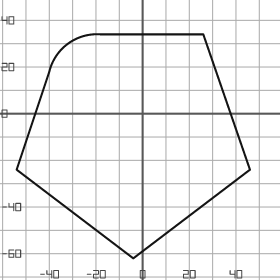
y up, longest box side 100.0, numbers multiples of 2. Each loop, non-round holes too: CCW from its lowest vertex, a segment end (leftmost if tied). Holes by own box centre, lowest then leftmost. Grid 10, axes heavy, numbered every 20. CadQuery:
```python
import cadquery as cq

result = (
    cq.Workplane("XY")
    .moveTo(-4.0, -62.0)
    .lineTo(46.0, -24.0)
    .lineTo(26.0, 34.0)
    .lineTo(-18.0, 34.0)
    .threePointArc((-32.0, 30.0), (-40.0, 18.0))
    .lineTo(-54.0, -24.0)
    .close()
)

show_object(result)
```